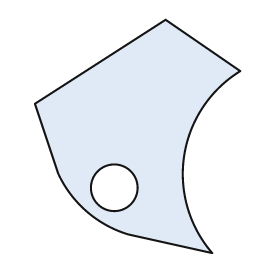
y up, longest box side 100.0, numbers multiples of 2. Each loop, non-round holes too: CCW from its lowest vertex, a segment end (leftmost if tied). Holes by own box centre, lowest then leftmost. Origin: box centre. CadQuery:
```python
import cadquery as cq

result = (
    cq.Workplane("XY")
    .moveTo(32.0, -50.0)
    .threePointArc((20.0, -8.0), (44.0, 28.0))
    .lineTo(12.0, 50.0)
    .lineTo(-44.0, 14.0)
    .lineTo(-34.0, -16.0)
    .threePointArc((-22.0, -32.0), (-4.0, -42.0))
    .close()
    .moveTo(-10.0, -22.0)
    .circle(10.0)
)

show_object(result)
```